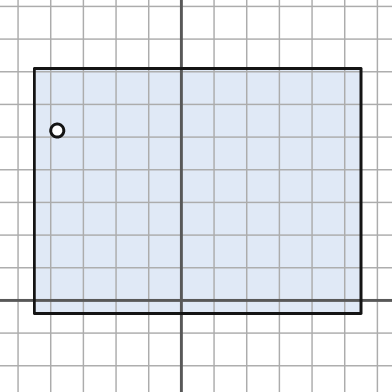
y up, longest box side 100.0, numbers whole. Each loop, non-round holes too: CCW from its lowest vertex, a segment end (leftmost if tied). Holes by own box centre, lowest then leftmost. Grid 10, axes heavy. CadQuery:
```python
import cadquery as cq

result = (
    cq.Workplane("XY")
    .moveTo(-45.0, -4.0)
    .lineTo(55.0, -4.0)
    .lineTo(55.0, 71.0)
    .lineTo(-45.0, 71.0)
    .close()
    .moveTo(-38.0, 52.0)
    .circle(2.0)
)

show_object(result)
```